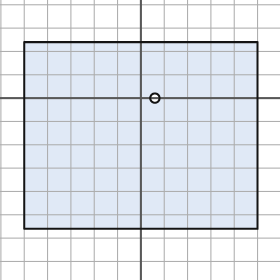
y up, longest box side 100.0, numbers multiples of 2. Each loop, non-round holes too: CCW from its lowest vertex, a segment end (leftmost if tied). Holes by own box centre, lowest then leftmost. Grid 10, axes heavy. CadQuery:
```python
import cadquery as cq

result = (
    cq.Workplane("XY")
    .moveTo(-50.0, -56.0)
    .lineTo(50.0, -56.0)
    .lineTo(50.0, 24.0)
    .lineTo(-50.0, 24.0)
    .close()
    .moveTo(6.0, 0.0)
    .circle(2.0)
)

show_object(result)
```